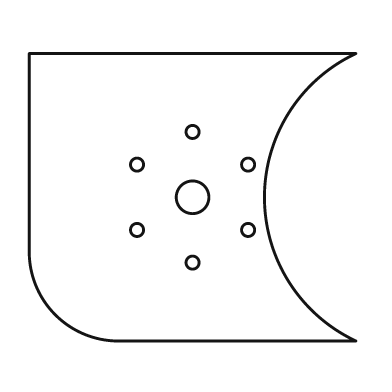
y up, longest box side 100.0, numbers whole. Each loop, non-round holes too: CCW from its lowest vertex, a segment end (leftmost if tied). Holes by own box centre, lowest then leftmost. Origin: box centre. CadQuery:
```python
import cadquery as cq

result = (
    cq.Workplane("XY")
    .moveTo(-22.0, -44.0)
    .lineTo(50.0, -44.0)
    .threePointArc((22.0, 0.0), (50.0, 44.0))
    .lineTo(-50.0, 44.0)
    .lineTo(-50.0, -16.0)
    .threePointArc((-42.0, -36.0), (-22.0, -44.0))
    .close()
    .moveTo(0.0, -20.0)
    .circle(2.0)
    .moveTo(-17.0, -10.0)
    .circle(2.0)
    .moveTo(17.0, -10.0)
    .circle(2.0)
    .moveTo(0.0, 0.0)
    .circle(5.0)
    .moveTo(-17.0, 10.0)
    .circle(2.0)
    .moveTo(17.0, 10.0)
    .circle(2.0)
    .moveTo(0.0, 20.0)
    .circle(2.0)
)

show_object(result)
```